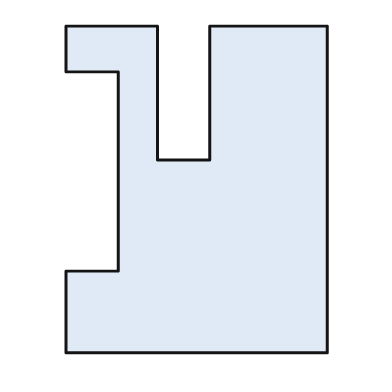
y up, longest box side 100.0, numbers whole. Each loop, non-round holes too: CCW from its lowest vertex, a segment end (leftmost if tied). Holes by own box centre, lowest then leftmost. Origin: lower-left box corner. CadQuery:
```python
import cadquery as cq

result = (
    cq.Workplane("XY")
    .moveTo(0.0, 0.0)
    .lineTo(80.0, 0.0)
    .lineTo(80.0, 100.0)
    .lineTo(44.0, 100.0)
    .lineTo(44.0, 59.0)
    .lineTo(28.0, 59.0)
    .lineTo(28.0, 100.0)
    .lineTo(0.0, 100.0)
    .lineTo(0.0, 86.0)
    .lineTo(16.0, 86.0)
    .lineTo(16.0, 25.0)
    .lineTo(0.0, 25.0)
    .close()
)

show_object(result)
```